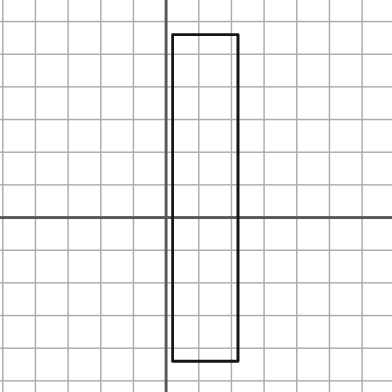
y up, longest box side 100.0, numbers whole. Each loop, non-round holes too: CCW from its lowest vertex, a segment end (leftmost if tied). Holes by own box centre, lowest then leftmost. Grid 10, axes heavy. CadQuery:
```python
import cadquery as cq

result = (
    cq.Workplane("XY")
    .moveTo(2.0, -44.0)
    .lineTo(22.0, -44.0)
    .lineTo(22.0, 56.0)
    .lineTo(2.0, 56.0)
    .close()
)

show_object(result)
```